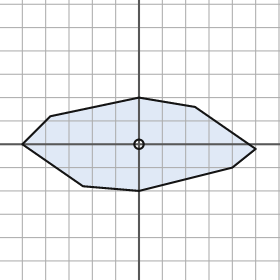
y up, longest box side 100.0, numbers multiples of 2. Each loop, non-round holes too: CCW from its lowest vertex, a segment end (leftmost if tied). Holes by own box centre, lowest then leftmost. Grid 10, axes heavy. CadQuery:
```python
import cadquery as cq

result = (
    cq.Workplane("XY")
    .moveTo(0.0, -20.0)
    .lineTo(40.0, -10.0)
    .lineTo(50.0, -2.0)
    .lineTo(24.0, 16.0)
    .lineTo(0.0, 20.0)
    .lineTo(-38.0, 12.0)
    .lineTo(-50.0, 0.0)
    .lineTo(-24.0, -18.0)
    .close()
    .moveTo(0.0, 0.0)
    .circle(2.0)
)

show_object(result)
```